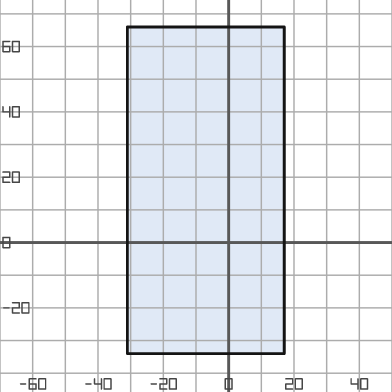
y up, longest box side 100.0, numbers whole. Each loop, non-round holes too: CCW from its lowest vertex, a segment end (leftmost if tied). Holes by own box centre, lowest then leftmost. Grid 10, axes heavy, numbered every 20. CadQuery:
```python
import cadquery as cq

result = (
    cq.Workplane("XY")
    .moveTo(-31.0, -34.0)
    .lineTo(17.0, -34.0)
    .lineTo(17.0, 66.0)
    .lineTo(-31.0, 66.0)
    .close()
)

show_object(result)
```